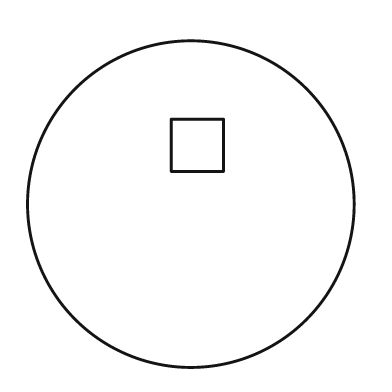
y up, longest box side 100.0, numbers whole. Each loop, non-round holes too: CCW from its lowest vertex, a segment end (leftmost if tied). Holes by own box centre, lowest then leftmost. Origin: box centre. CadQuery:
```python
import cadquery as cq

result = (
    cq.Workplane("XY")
    .moveTo(0.0, 0.0)
    .circle(50.0)
    .moveTo(-6.0, 10.0)
    .lineTo(10.0, 10.0)
    .lineTo(10.0, 26.0)
    .lineTo(-6.0, 26.0)
    .close()
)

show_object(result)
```